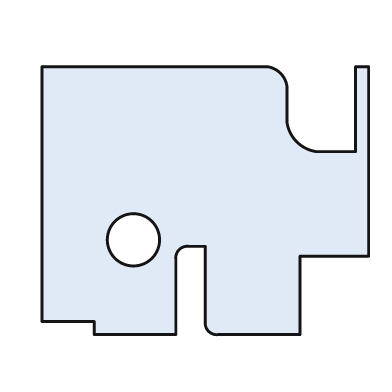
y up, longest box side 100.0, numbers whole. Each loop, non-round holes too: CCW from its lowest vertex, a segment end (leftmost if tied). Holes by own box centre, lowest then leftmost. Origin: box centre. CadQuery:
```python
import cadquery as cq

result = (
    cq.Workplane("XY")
    .moveTo(-34.0, -41.0)
    .lineTo(-9.0, -41.0)
    .lineTo(-9.0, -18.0)
    .threePointArc((-8.0, -15.0), (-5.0, -14.0))
    .lineTo(0.0, -14.0)
    .lineTo(0.0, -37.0)
    .threePointArc((1.0, -40.0), (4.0, -41.0))
    .lineTo(29.0, -41.0)
    .lineTo(29.0, -17.0)
    .lineTo(50.0, -17.0)
    .lineTo(50.0, 41.0)
    .lineTo(46.0, 41.0)
    .lineTo(46.0, 15.0)
    .lineTo(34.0, 15.0)
    .threePointArc((28.0, 18.0), (25.0, 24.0))
    .lineTo(25.0, 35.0)
    .threePointArc((23.0, 39.0), (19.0, 41.0))
    .lineTo(-50.0, 41.0)
    .lineTo(-50.0, -37.0)
    .lineTo(-34.0, -37.0)
    .close()
    .moveTo(-22.0, -12.0)
    .circle(8.0)
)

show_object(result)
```